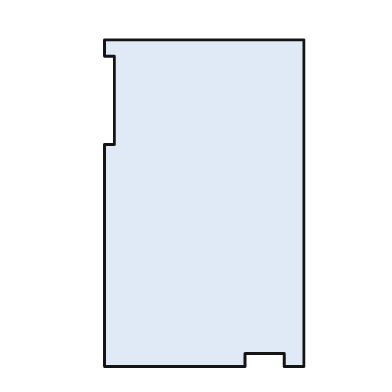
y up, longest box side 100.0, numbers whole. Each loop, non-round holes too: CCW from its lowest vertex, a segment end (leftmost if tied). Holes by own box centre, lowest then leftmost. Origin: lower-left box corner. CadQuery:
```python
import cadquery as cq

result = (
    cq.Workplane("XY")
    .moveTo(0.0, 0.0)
    .lineTo(43.0, 0.0)
    .lineTo(43.0, 4.0)
    .lineTo(55.0, 4.0)
    .lineTo(55.0, 0.0)
    .lineTo(61.0, 0.0)
    .lineTo(61.0, 100.0)
    .lineTo(0.0, 100.0)
    .lineTo(0.0, 95.0)
    .lineTo(3.0, 95.0)
    .lineTo(3.0, 68.0)
    .lineTo(0.0, 68.0)
    .close()
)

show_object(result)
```